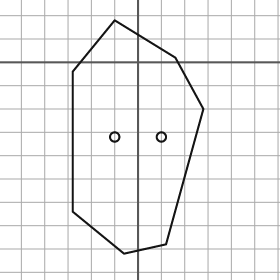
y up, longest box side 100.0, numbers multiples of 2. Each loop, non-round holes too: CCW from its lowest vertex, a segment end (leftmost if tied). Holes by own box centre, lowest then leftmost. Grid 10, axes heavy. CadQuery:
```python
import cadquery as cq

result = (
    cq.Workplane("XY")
    .moveTo(-6.0, -82.0)
    .lineTo(12.0, -78.0)
    .lineTo(28.0, -20.0)
    .lineTo(16.0, 2.0)
    .lineTo(-10.0, 18.0)
    .lineTo(-28.0, -4.0)
    .lineTo(-28.0, -64.0)
    .close()
    .moveTo(-10.0, -32.0)
    .circle(2.0)
    .moveTo(10.0, -32.0)
    .circle(2.0)
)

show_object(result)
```